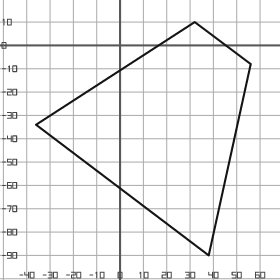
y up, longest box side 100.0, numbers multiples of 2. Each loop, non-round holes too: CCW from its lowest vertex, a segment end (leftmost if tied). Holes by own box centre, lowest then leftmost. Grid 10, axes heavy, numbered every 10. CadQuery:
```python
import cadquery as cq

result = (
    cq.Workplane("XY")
    .moveTo(38.0, -90.0)
    .lineTo(56.0, -8.0)
    .lineTo(32.0, 10.0)
    .lineTo(-36.0, -34.0)
    .close()
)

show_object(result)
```